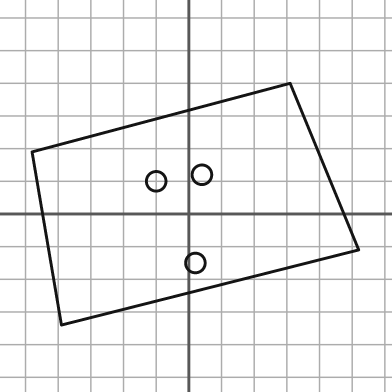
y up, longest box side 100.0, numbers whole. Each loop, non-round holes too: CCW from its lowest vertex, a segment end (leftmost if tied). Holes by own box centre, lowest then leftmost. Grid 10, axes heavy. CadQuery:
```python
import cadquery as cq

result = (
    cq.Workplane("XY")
    .moveTo(-39.0, -34.0)
    .lineTo(52.0, -11.0)
    .lineTo(31.0, 40.0)
    .lineTo(-48.0, 19.0)
    .close()
    .moveTo(2.0, -15.0)
    .circle(3.0)
    .moveTo(-10.0, 10.0)
    .circle(3.0)
    .moveTo(4.0, 12.0)
    .circle(3.0)
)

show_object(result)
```